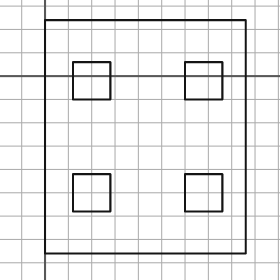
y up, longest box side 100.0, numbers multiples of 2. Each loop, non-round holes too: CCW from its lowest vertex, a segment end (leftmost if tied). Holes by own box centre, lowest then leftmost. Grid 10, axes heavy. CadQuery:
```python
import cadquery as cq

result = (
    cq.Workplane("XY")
    .moveTo(0.0, -76.0)
    .lineTo(86.0, -76.0)
    .lineTo(86.0, 24.0)
    .lineTo(0.0, 24.0)
    .close()
    .moveTo(12.0, -58.0)
    .lineTo(28.0, -58.0)
    .lineTo(28.0, -42.0)
    .lineTo(12.0, -42.0)
    .close()
    .moveTo(60.0, -58.0)
    .lineTo(76.0, -58.0)
    .lineTo(76.0, -42.0)
    .lineTo(60.0, -42.0)
    .close()
    .moveTo(12.0, -10.0)
    .lineTo(28.0, -10.0)
    .lineTo(28.0, 6.0)
    .lineTo(12.0, 6.0)
    .close()
    .moveTo(60.0, -10.0)
    .lineTo(76.0, -10.0)
    .lineTo(76.0, 6.0)
    .lineTo(60.0, 6.0)
    .close()
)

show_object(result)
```